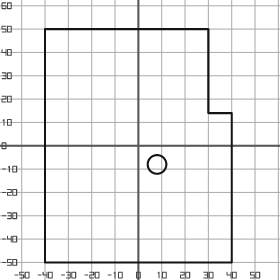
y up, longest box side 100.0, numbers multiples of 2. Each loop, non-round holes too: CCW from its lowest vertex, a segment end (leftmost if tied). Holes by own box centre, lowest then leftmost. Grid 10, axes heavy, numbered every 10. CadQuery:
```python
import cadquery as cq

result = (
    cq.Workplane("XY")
    .moveTo(-40.0, -50.0)
    .lineTo(40.0, -50.0)
    .lineTo(40.0, 14.0)
    .lineTo(30.0, 14.0)
    .lineTo(30.0, 50.0)
    .lineTo(-40.0, 50.0)
    .close()
    .moveTo(8.0, -8.0)
    .circle(4.0)
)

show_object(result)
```